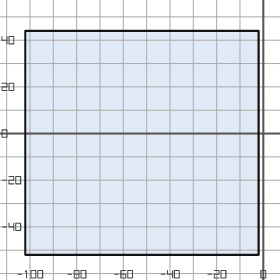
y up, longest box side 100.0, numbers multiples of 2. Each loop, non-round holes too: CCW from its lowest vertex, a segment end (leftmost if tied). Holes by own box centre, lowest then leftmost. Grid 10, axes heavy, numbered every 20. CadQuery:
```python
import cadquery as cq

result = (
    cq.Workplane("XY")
    .moveTo(-102.0, -52.0)
    .lineTo(-2.0, -52.0)
    .lineTo(-2.0, 44.0)
    .lineTo(-102.0, 44.0)
    .close()
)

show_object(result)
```